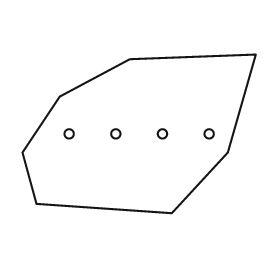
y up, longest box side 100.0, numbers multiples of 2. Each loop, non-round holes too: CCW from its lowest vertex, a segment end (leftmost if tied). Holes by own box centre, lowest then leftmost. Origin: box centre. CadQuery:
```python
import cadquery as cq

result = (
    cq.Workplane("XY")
    .moveTo(14.0, -34.0)
    .lineTo(38.0, -8.0)
    .lineTo(50.0, 34.0)
    .lineTo(-4.0, 32.0)
    .lineTo(-34.0, 16.0)
    .lineTo(-50.0, -8.0)
    .lineTo(-44.0, -30.0)
    .close()
    .moveTo(-30.0, 0.0)
    .circle(2.0)
    .moveTo(-10.0, 0.0)
    .circle(2.0)
    .moveTo(10.0, 0.0)
    .circle(2.0)
    .moveTo(30.0, 0.0)
    .circle(2.0)
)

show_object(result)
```